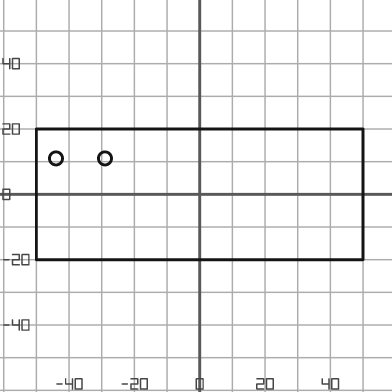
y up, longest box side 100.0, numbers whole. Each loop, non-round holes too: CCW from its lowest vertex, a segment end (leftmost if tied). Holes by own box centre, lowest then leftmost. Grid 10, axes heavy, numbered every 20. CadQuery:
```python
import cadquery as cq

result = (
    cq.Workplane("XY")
    .moveTo(-50.0, -20.0)
    .lineTo(50.0, -20.0)
    .lineTo(50.0, 20.0)
    .lineTo(-50.0, 20.0)
    .close()
    .moveTo(-44.0, 11.0)
    .circle(2.0)
    .moveTo(-29.0, 11.0)
    .circle(2.0)
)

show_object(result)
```